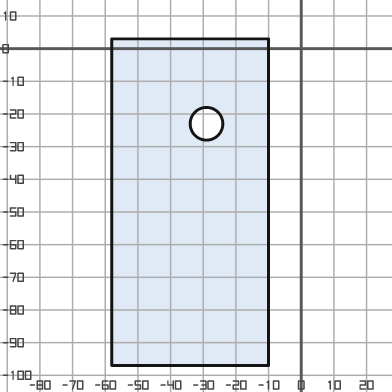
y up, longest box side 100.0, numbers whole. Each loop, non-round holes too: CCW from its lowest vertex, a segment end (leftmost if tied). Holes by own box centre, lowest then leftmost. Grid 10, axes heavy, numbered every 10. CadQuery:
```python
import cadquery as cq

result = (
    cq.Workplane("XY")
    .moveTo(-58.0, -97.0)
    .lineTo(-10.0, -97.0)
    .lineTo(-10.0, 3.0)
    .lineTo(-58.0, 3.0)
    .close()
    .moveTo(-29.0, -23.0)
    .circle(5.0)
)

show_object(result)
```